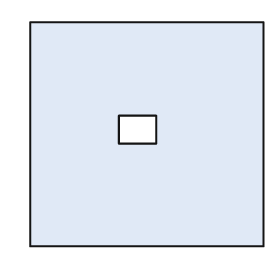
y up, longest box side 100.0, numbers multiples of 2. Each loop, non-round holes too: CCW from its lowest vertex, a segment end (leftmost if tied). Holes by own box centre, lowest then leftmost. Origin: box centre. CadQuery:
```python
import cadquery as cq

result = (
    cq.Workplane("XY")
    .moveTo(-50.0, -48.0)
    .lineTo(50.0, -48.0)
    .lineTo(50.0, 48.0)
    .lineTo(-50.0, 48.0)
    .close()
    .moveTo(-12.0, -4.0)
    .lineTo(4.0, -4.0)
    .lineTo(4.0, 8.0)
    .lineTo(-12.0, 8.0)
    .close()
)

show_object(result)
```